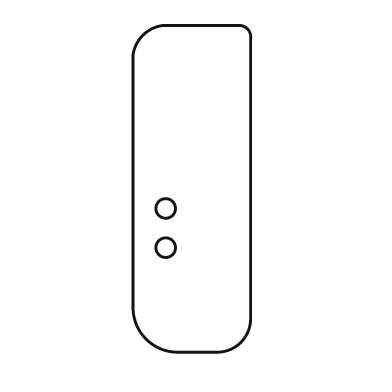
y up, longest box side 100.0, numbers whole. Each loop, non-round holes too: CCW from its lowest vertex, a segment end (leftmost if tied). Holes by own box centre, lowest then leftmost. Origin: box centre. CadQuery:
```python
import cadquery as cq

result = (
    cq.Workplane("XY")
    .moveTo(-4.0, -50.0)
    .lineTo(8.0, -50.0)
    .threePointArc((15.0, -47.0), (18.0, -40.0))
    .lineTo(18.0, 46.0)
    .threePointArc((17.0, 49.0), (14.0, 50.0))
    .lineTo(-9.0, 50.0)
    .threePointArc((-15.0, 47.0), (-18.0, 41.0))
    .lineTo(-18.0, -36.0)
    .threePointArc((-14.0, -46.0), (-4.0, -50.0))
    .close()
    .moveTo(-8.0, -18.0)
    .circle(3.0)
    .moveTo(-8.0, -6.0)
    .circle(3.0)
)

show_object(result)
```